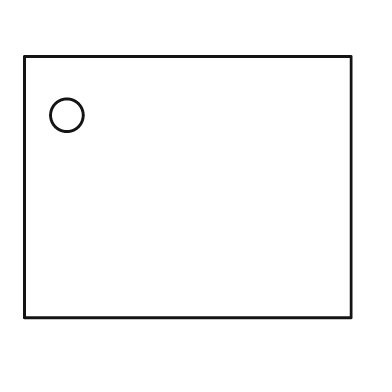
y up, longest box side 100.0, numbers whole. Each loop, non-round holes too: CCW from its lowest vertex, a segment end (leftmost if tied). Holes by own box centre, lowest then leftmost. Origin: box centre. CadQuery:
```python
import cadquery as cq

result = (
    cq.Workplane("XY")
    .moveTo(-50.0, -40.0)
    .lineTo(50.0, -40.0)
    .lineTo(50.0, 40.0)
    .lineTo(-50.0, 40.0)
    .close()
    .moveTo(-37.0, 22.0)
    .circle(5.0)
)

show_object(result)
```